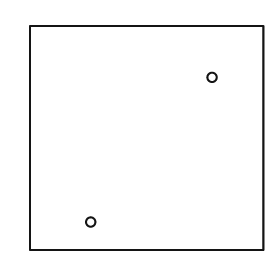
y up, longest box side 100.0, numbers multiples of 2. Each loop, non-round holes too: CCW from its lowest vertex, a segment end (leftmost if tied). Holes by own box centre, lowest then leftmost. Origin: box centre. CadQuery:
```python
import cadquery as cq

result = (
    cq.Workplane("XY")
    .moveTo(-50.0, -48.0)
    .lineTo(50.0, -48.0)
    .lineTo(50.0, 48.0)
    .lineTo(-50.0, 48.0)
    .close()
    .moveTo(-24.0, -36.0)
    .circle(2.0)
    .moveTo(28.0, 26.0)
    .circle(2.0)
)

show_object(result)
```